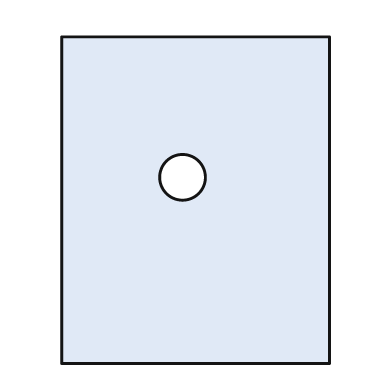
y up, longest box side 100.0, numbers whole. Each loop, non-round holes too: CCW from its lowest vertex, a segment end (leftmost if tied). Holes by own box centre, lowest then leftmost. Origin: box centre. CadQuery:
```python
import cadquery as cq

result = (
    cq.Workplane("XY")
    .moveTo(-41.0, -50.0)
    .lineTo(41.0, -50.0)
    .lineTo(41.0, 50.0)
    .lineTo(-41.0, 50.0)
    .close()
    .moveTo(-4.0, 7.0)
    .circle(7.0)
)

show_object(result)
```